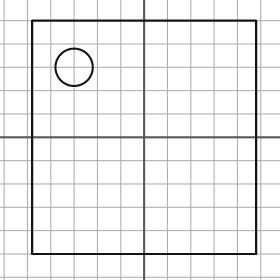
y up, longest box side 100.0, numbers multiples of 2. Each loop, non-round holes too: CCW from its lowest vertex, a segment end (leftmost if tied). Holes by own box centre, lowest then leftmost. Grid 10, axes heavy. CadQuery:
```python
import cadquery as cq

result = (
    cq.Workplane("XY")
    .moveTo(-48.0, -50.0)
    .lineTo(48.0, -50.0)
    .lineTo(48.0, 50.0)
    .lineTo(-48.0, 50.0)
    .close()
    .moveTo(-30.0, 30.0)
    .circle(8.0)
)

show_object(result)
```